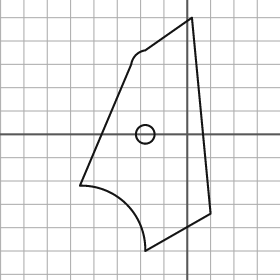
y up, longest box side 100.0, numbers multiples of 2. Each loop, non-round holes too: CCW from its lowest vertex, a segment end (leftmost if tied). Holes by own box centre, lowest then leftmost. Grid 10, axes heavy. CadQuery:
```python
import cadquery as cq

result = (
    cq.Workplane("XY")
    .moveTo(-18.0, -50.0)
    .lineTo(10.0, -34.0)
    .lineTo(2.0, 50.0)
    .lineTo(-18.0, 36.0)
    .threePointArc((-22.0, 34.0), (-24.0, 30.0))
    .lineTo(-46.0, -22.0)
    .threePointArc((-26.0, -30.0), (-18.0, -50.0))
    .close()
    .moveTo(-18.0, 0.0)
    .circle(4.0)
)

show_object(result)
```